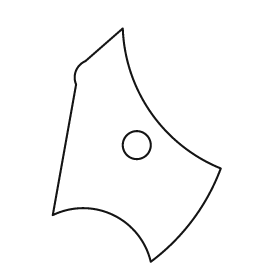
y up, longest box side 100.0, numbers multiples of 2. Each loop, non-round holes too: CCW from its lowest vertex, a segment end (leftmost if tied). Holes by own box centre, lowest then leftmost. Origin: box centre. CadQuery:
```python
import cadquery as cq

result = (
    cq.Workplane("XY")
    .moveTo(6.0, -50.0)
    .threePointArc((24.0, -32.0), (36.0, -10.0))
    .threePointArc((6.0, 14.0), (-6.0, 50.0))
    .lineTo(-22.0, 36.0)
    .threePointArc((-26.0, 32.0), (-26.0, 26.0))
    .lineTo(-36.0, -30.0)
    .threePointArc((-10.0, -30.0), (6.0, -50.0))
    .close()
    .moveTo(0.0, 0.0)
    .circle(6.0)
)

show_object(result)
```